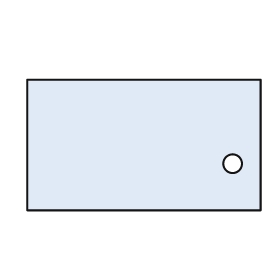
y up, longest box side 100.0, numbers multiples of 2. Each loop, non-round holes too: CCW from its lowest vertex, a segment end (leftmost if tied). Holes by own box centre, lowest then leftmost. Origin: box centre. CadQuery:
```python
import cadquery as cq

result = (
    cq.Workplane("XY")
    .moveTo(-50.0, -28.0)
    .lineTo(50.0, -28.0)
    .lineTo(50.0, 28.0)
    .lineTo(-50.0, 28.0)
    .close()
    .moveTo(38.0, -8.0)
    .circle(4.0)
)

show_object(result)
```